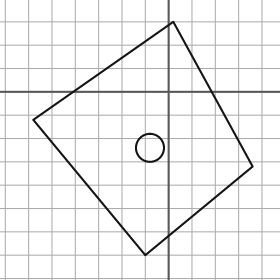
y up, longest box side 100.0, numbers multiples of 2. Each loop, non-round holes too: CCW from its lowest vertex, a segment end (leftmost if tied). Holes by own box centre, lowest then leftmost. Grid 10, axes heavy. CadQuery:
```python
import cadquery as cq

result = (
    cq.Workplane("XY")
    .moveTo(-10.0, -70.0)
    .lineTo(36.0, -32.0)
    .lineTo(2.0, 30.0)
    .lineTo(-58.0, -12.0)
    .close()
    .moveTo(-8.0, -24.0)
    .circle(6.0)
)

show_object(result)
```